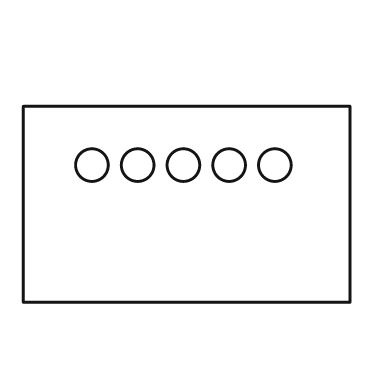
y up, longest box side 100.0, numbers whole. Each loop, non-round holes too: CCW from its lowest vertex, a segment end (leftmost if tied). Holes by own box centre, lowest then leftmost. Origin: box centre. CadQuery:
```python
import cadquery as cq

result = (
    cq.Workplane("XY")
    .moveTo(-50.0, -30.0)
    .lineTo(50.0, -30.0)
    .lineTo(50.0, 30.0)
    .lineTo(-50.0, 30.0)
    .close()
    .moveTo(-29.0, 12.0)
    .circle(5.0)
    .moveTo(-15.0, 12.0)
    .circle(5.0)
    .moveTo(-1.0, 12.0)
    .circle(5.0)
    .moveTo(13.0, 12.0)
    .circle(5.0)
    .moveTo(27.0, 12.0)
    .circle(5.0)
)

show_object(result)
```